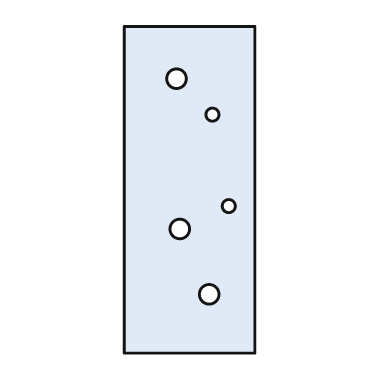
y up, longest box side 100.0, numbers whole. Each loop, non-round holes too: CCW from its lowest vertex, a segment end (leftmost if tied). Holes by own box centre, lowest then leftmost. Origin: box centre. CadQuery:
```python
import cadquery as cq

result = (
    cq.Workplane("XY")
    .moveTo(-20.0, -50.0)
    .lineTo(20.0, -50.0)
    .lineTo(20.0, 50.0)
    .lineTo(-20.0, 50.0)
    .close()
    .moveTo(6.0, -32.0)
    .circle(3.0)
    .moveTo(-3.0, -12.0)
    .circle(3.0)
    .moveTo(12.0, -5.0)
    .circle(2.0)
    .moveTo(7.0, 23.0)
    .circle(2.0)
    .moveTo(-4.0, 34.0)
    .circle(3.0)
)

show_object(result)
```